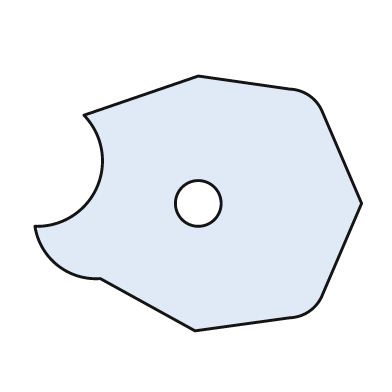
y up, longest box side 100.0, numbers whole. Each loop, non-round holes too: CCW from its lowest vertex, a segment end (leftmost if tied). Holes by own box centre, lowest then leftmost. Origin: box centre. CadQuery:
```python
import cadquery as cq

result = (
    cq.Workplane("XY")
    .moveTo(-1.0, -39.0)
    .lineTo(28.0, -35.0)
    .threePointArc((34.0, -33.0), (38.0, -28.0))
    .lineTo(50.0, 0.0)
    .lineTo(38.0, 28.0)
    .threePointArc((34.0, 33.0), (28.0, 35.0))
    .lineTo(0.0, 39.0)
    .lineTo(-35.0, 27.0)
    .threePointArc((-31.0, 5.0), (-50.0, -7.0))
    .threePointArc((-43.0, -19.0), (-30.0, -23.0))
    .close()
    .moveTo(0.0, 0.0)
    .circle(7.0)
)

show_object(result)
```